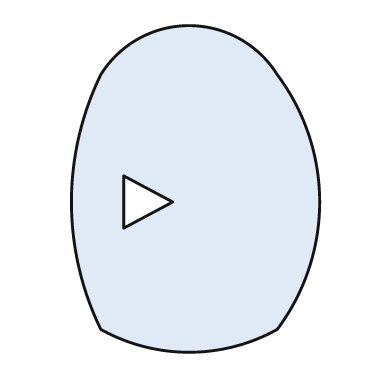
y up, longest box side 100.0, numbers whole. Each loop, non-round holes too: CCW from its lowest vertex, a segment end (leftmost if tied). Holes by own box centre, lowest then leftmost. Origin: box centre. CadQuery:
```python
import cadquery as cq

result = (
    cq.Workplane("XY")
    .moveTo(-29.0, -43.0)
    .threePointArc((-2.0, -50.0), (25.0, -43.0))
    .threePointArc((38.0, -4.0), (25.0, 35.0))
    .threePointArc((-2.0, 50.0), (-29.0, 35.0))
    .threePointArc((-38.0, -4.0), (-29.0, -43.0))
    .close()
    .moveTo(-22.0, -12.0)
    .lineTo(-7.0, -4.0)
    .lineTo(-22.0, 4.0)
    .close()
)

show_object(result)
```